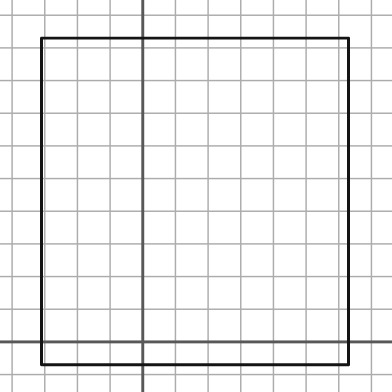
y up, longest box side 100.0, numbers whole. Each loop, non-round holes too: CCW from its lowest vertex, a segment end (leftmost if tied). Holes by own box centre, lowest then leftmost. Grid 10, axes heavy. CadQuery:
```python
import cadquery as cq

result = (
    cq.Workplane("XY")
    .moveTo(-31.0, -7.0)
    .lineTo(63.0, -7.0)
    .lineTo(63.0, 93.0)
    .lineTo(-31.0, 93.0)
    .close()
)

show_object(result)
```